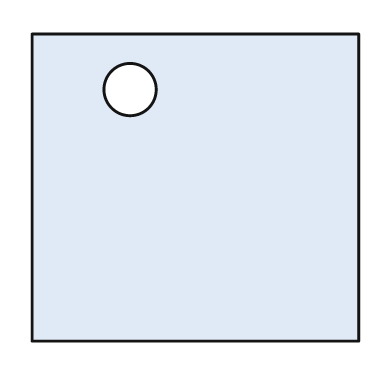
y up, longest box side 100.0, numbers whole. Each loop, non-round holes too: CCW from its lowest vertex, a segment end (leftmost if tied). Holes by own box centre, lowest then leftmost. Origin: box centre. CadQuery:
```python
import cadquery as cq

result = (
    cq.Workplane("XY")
    .moveTo(-50.0, -47.0)
    .lineTo(50.0, -47.0)
    .lineTo(50.0, 47.0)
    .lineTo(-50.0, 47.0)
    .close()
    .moveTo(-20.0, 30.0)
    .circle(8.0)
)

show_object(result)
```